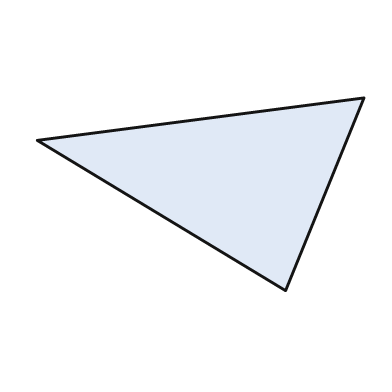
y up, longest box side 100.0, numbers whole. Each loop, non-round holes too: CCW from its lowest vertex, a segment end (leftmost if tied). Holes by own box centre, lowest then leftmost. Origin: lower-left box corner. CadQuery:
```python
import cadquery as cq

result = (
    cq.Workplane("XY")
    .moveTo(76.0, 0.0)
    .lineTo(100.0, 59.0)
    .lineTo(0.0, 46.0)
    .close()
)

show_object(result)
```